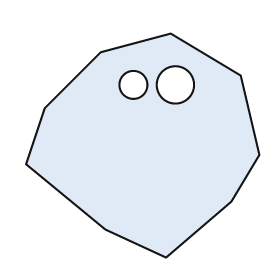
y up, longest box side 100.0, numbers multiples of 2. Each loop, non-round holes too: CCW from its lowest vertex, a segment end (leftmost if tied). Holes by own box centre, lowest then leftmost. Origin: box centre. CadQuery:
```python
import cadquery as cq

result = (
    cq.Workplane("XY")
    .moveTo(10.0, -48.0)
    .lineTo(38.0, -24.0)
    .lineTo(50.0, -4.0)
    .lineTo(42.0, 30.0)
    .lineTo(12.0, 48.0)
    .lineTo(-18.0, 40.0)
    .lineTo(-42.0, 16.0)
    .lineTo(-50.0, -8.0)
    .lineTo(-16.0, -36.0)
    .close()
    .moveTo(-4.0, 26.0)
    .circle(6.0)
    .moveTo(14.0, 26.0)
    .circle(8.0)
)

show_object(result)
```